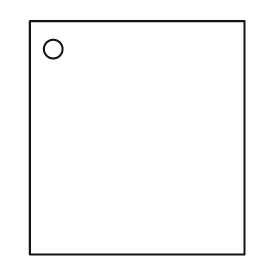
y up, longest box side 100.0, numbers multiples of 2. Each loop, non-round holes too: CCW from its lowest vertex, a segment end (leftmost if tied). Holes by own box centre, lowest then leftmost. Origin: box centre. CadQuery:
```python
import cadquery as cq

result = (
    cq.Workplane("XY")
    .moveTo(-46.0, -50.0)
    .lineTo(46.0, -50.0)
    .lineTo(46.0, 50.0)
    .lineTo(-46.0, 50.0)
    .close()
    .moveTo(-36.0, 38.0)
    .circle(4.0)
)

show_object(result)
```